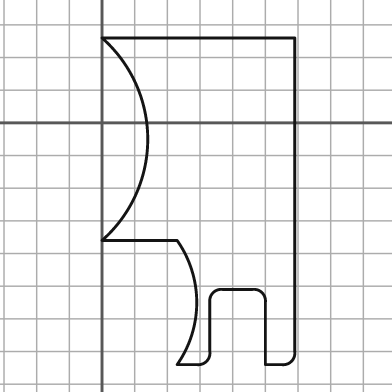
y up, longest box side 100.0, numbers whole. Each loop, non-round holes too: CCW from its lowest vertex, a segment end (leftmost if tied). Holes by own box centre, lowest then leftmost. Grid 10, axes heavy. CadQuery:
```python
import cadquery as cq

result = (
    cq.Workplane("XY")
    .moveTo(23.0, -74.0)
    .lineTo(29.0, -74.0)
    .threePointArc((32.0, -73.0), (33.0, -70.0))
    .lineTo(33.0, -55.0)
    .threePointArc((34.0, -52.0), (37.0, -51.0))
    .lineTo(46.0, -51.0)
    .threePointArc((49.0, -52.0), (50.0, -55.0))
    .lineTo(50.0, -74.0)
    .lineTo(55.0, -74.0)
    .threePointArc((58.0, -73.0), (59.0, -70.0))
    .lineTo(59.0, 26.0)
    .lineTo(0.0, 26.0)
    .threePointArc((14.0, -5.0), (0.0, -36.0))
    .lineTo(23.0, -36.0)
    .threePointArc((29.0, -55.0), (23.0, -74.0))
    .close()
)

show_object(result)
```